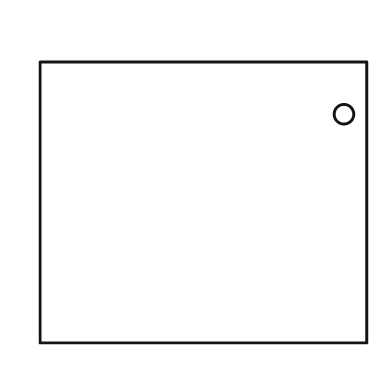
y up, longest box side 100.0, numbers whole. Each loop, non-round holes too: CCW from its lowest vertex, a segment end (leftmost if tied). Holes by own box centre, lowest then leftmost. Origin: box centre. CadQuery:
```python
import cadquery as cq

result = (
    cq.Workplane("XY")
    .moveTo(-50.0, -43.0)
    .lineTo(50.0, -43.0)
    .lineTo(50.0, 43.0)
    .lineTo(-50.0, 43.0)
    .close()
    .moveTo(43.0, 27.0)
    .circle(3.0)
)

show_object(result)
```